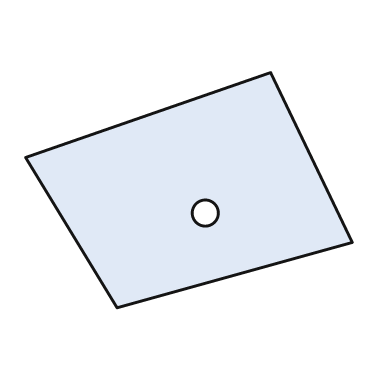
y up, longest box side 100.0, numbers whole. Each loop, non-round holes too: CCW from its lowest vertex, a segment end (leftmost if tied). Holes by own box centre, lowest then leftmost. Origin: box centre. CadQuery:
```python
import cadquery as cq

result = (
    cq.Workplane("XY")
    .moveTo(-22.0, -36.0)
    .lineTo(50.0, -16.0)
    .lineTo(25.0, 36.0)
    .lineTo(-50.0, 10.0)
    .close()
    .moveTo(5.0, -7.0)
    .circle(4.0)
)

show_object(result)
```